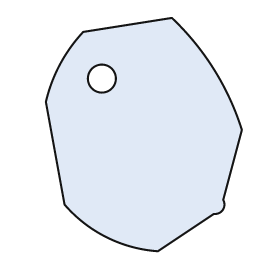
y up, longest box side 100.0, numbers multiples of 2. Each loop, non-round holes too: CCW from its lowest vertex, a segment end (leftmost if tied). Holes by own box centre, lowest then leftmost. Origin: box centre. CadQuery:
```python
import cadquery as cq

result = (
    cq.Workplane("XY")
    .moveTo(6.0, -50.0)
    .lineTo(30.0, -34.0)
    .threePointArc((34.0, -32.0), (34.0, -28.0))
    .lineTo(42.0, 2.0)
    .threePointArc((30.0, 28.0), (12.0, 50.0))
    .lineTo(-26.0, 44.0)
    .threePointArc((-36.0, 30.0), (-42.0, 14.0))
    .lineTo(-34.0, -30.0)
    .threePointArc((-16.0, -44.0), (6.0, -50.0))
    .close()
    .moveTo(-18.0, 24.0)
    .circle(6.0)
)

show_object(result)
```